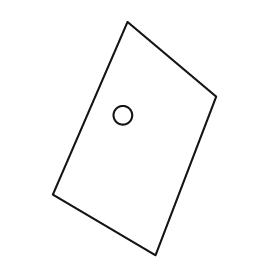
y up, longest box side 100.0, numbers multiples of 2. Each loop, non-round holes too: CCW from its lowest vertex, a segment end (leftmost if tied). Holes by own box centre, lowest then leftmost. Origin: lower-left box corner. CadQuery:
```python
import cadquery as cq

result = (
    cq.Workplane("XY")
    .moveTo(44.0, 0.0)
    .lineTo(70.0, 68.0)
    .lineTo(32.0, 100.0)
    .lineTo(0.0, 26.0)
    .close()
    .moveTo(30.0, 60.0)
    .circle(4.0)
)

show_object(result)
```